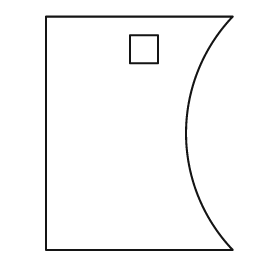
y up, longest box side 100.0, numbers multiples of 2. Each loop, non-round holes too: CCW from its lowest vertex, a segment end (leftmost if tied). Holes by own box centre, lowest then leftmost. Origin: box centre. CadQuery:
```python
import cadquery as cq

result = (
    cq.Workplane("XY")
    .moveTo(-40.0, -50.0)
    .lineTo(40.0, -50.0)
    .threePointArc((20.0, 0.0), (40.0, 50.0))
    .lineTo(-40.0, 50.0)
    .close()
    .moveTo(-4.0, 30.0)
    .lineTo(8.0, 30.0)
    .lineTo(8.0, 42.0)
    .lineTo(-4.0, 42.0)
    .close()
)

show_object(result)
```